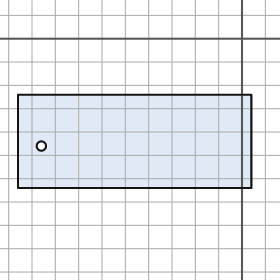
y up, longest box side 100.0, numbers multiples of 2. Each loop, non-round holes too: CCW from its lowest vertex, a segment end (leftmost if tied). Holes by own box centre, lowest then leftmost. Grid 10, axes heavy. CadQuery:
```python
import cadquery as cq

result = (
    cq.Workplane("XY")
    .moveTo(-96.0, -64.0)
    .lineTo(4.0, -64.0)
    .lineTo(4.0, -24.0)
    .lineTo(-96.0, -24.0)
    .close()
    .moveTo(-86.0, -46.0)
    .circle(2.0)
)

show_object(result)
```